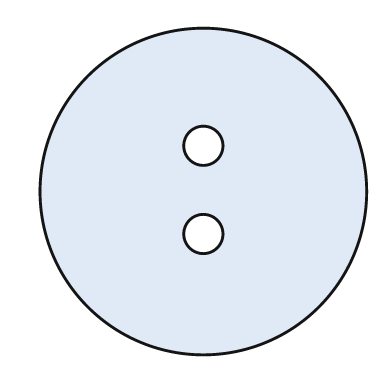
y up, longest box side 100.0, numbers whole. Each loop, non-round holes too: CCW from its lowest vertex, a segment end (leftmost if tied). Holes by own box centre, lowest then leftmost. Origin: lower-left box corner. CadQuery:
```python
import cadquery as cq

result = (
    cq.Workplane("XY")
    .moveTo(50.0, 50.0)
    .circle(50.0)
    .moveTo(50.0, 37.0)
    .circle(6.0)
    .moveTo(50.0, 64.0)
    .circle(6.0)
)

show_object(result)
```